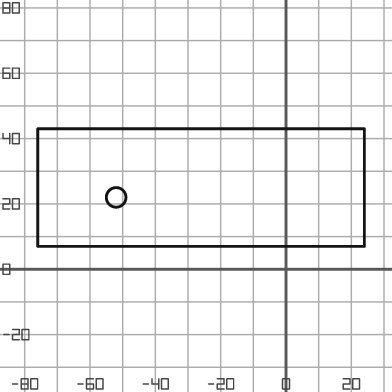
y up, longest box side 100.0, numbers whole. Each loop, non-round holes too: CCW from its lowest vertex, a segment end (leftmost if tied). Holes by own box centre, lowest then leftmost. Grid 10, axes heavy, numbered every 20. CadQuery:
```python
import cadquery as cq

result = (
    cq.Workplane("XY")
    .moveTo(-76.0, 7.0)
    .lineTo(24.0, 7.0)
    .lineTo(24.0, 43.0)
    .lineTo(-76.0, 43.0)
    .close()
    .moveTo(-52.0, 22.0)
    .circle(3.0)
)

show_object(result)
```